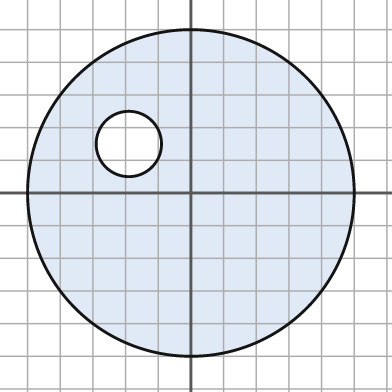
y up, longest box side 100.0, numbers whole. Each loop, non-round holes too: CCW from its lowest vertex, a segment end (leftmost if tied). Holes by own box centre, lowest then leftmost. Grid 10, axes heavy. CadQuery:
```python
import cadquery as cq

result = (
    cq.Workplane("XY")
    .moveTo(0.0, 0.0)
    .circle(50.0)
    .moveTo(-19.0, 15.0)
    .circle(10.0)
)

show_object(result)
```